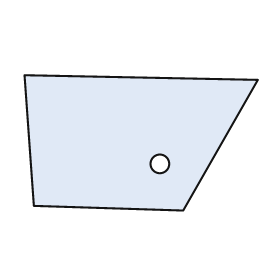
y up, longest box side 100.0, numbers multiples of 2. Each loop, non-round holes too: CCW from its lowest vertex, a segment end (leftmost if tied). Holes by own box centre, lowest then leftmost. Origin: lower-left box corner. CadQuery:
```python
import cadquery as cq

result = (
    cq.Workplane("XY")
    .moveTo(68.0, 0.0)
    .lineTo(100.0, 56.0)
    .lineTo(0.0, 58.0)
    .lineTo(4.0, 2.0)
    .close()
    .moveTo(58.0, 20.0)
    .circle(4.0)
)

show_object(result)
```